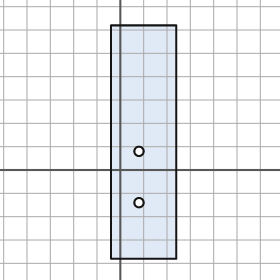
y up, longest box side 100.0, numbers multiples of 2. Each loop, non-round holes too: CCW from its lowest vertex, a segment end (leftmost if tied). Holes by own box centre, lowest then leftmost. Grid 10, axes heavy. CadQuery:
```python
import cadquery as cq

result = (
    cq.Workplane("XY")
    .moveTo(-4.0, -38.0)
    .lineTo(24.0, -38.0)
    .lineTo(24.0, 62.0)
    .lineTo(-4.0, 62.0)
    .close()
    .moveTo(8.0, -14.0)
    .circle(2.0)
    .moveTo(8.0, 8.0)
    .circle(2.0)
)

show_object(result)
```